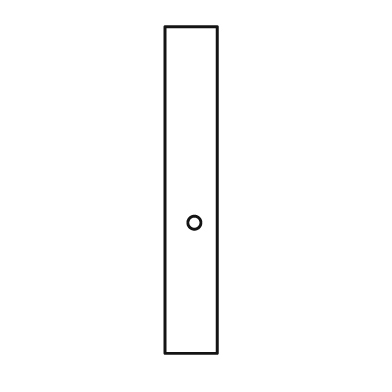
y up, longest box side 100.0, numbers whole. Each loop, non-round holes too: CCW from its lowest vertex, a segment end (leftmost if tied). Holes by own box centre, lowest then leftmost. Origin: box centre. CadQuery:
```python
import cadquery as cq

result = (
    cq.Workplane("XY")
    .moveTo(-8.0, -50.0)
    .lineTo(8.0, -50.0)
    .lineTo(8.0, 50.0)
    .lineTo(-8.0, 50.0)
    .close()
    .moveTo(1.0, -10.0)
    .circle(2.0)
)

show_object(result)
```